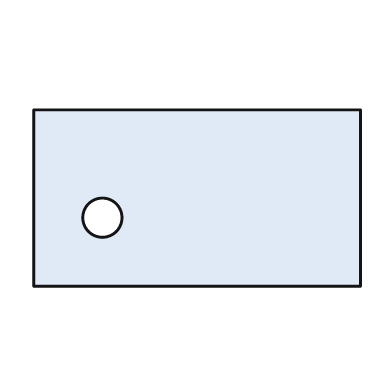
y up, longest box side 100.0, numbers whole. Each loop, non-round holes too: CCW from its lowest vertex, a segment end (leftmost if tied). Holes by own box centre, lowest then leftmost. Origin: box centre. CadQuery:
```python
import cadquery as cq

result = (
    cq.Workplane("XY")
    .moveTo(-50.0, -27.0)
    .lineTo(50.0, -27.0)
    .lineTo(50.0, 27.0)
    .lineTo(-50.0, 27.0)
    .close()
    .moveTo(-29.0, -6.0)
    .circle(6.0)
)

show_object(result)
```